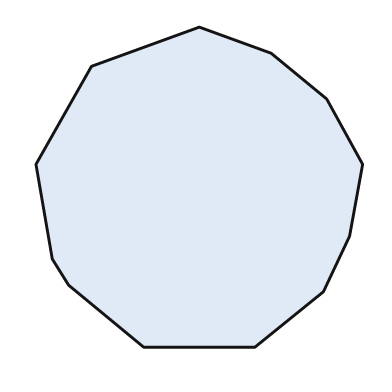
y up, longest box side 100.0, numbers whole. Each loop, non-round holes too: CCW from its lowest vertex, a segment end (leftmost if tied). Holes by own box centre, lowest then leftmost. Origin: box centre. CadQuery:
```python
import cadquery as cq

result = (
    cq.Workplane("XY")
    .moveTo(-17.0, -49.0)
    .lineTo(17.0, -49.0)
    .lineTo(38.0, -32.0)
    .lineTo(46.0, -15.0)
    .lineTo(50.0, 7.0)
    .lineTo(39.0, 27.0)
    .lineTo(22.0, 41.0)
    .lineTo(0.0, 49.0)
    .lineTo(-33.0, 37.0)
    .lineTo(-50.0, 7.0)
    .lineTo(-45.0, -22.0)
    .lineTo(-40.0, -30.0)
    .close()
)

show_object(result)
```